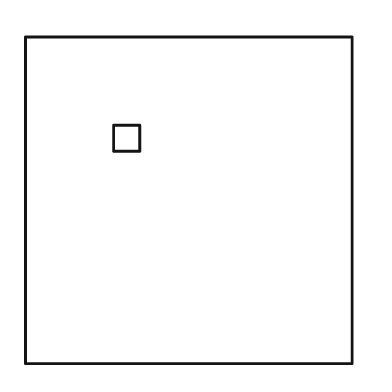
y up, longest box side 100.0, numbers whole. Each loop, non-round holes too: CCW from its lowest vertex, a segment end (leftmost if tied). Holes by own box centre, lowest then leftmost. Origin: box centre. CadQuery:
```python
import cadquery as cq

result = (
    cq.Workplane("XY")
    .moveTo(-50.0, -50.0)
    .lineTo(50.0, -50.0)
    .lineTo(50.0, 50.0)
    .lineTo(-50.0, 50.0)
    .close()
    .moveTo(-23.0, 15.0)
    .lineTo(-15.0, 15.0)
    .lineTo(-15.0, 23.0)
    .lineTo(-23.0, 23.0)
    .close()
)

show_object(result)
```